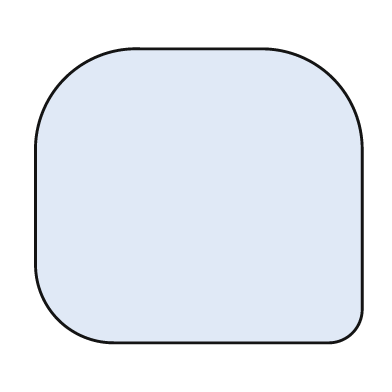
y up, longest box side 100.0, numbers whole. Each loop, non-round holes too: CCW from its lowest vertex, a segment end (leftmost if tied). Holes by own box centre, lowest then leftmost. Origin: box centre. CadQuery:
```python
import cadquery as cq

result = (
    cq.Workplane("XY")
    .moveTo(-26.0, -45.0)
    .lineTo(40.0, -45.0)
    .threePointArc((47.0, -42.0), (50.0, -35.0))
    .lineTo(50.0, 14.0)
    .threePointArc((41.0, 36.0), (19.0, 45.0))
    .lineTo(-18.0, 45.0)
    .threePointArc((-41.0, 36.0), (-50.0, 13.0))
    .lineTo(-50.0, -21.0)
    .threePointArc((-43.0, -38.0), (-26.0, -45.0))
    .close()
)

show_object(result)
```